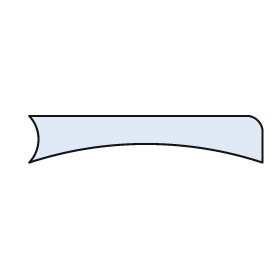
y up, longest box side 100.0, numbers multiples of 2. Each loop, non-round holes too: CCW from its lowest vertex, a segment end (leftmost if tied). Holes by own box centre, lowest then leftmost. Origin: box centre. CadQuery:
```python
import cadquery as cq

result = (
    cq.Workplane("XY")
    .moveTo(-50.0, -10.0)
    .threePointArc((0.0, -2.0), (50.0, -10.0))
    .lineTo(50.0, 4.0)
    .threePointArc((48.0, 8.0), (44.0, 10.0))
    .lineTo(-50.0, 10.0)
    .threePointArc((-46.0, 0.0), (-50.0, -10.0))
    .close()
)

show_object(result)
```